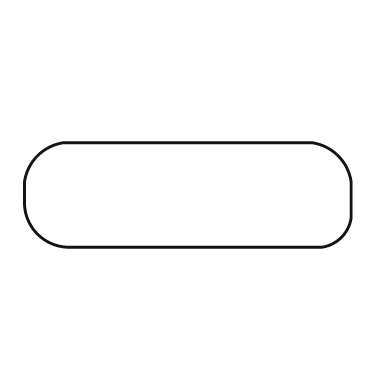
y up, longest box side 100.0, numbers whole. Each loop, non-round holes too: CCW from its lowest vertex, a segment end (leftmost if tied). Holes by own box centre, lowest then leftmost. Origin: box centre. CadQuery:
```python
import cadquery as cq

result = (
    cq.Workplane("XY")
    .moveTo(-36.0, -16.0)
    .lineTo(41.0, -16.0)
    .threePointArc((47.0, -13.0), (50.0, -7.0))
    .lineTo(50.0, 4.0)
    .threePointArc((46.0, 12.0), (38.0, 16.0))
    .lineTo(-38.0, 16.0)
    .threePointArc((-46.0, 12.0), (-50.0, 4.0))
    .lineTo(-50.0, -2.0)
    .threePointArc((-46.0, -12.0), (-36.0, -16.0))
    .close()
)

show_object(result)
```